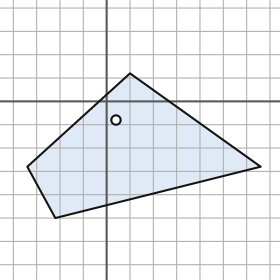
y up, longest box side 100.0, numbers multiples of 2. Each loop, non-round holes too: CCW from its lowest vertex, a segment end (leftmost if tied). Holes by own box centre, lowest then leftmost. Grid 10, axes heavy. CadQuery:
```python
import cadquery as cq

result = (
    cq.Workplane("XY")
    .moveTo(-22.0, -50.0)
    .lineTo(66.0, -28.0)
    .lineTo(10.0, 12.0)
    .lineTo(-34.0, -28.0)
    .close()
    .moveTo(4.0, -8.0)
    .circle(2.0)
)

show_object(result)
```